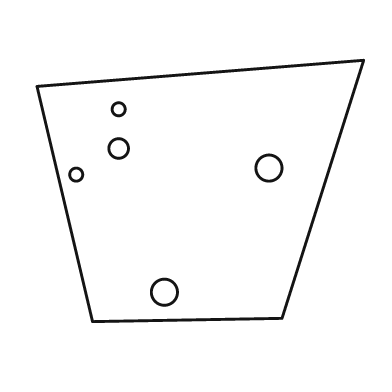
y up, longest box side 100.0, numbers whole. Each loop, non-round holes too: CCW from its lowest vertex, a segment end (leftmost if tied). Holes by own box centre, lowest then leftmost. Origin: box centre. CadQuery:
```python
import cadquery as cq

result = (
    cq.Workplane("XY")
    .moveTo(-33.0, -40.0)
    .lineTo(25.0, -39.0)
    .lineTo(50.0, 40.0)
    .lineTo(-50.0, 32.0)
    .close()
    .moveTo(-11.0, -31.0)
    .circle(4.0)
    .moveTo(-38.0, 5.0)
    .circle(2.0)
    .moveTo(21.0, 7.0)
    .circle(4.0)
    .moveTo(-25.0, 13.0)
    .circle(3.0)
    .moveTo(-25.0, 25.0)
    .circle(2.0)
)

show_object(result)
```